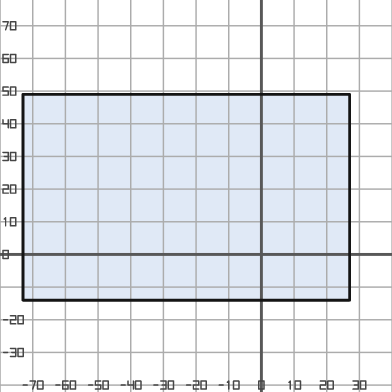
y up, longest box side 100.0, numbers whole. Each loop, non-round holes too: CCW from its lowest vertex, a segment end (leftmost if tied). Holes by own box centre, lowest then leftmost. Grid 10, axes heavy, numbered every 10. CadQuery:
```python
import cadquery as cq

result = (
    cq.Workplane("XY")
    .moveTo(-73.0, -14.0)
    .lineTo(27.0, -14.0)
    .lineTo(27.0, 49.0)
    .lineTo(-73.0, 49.0)
    .close()
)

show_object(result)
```